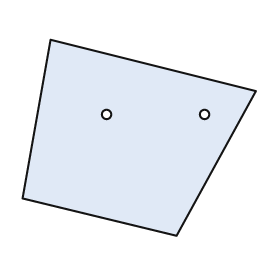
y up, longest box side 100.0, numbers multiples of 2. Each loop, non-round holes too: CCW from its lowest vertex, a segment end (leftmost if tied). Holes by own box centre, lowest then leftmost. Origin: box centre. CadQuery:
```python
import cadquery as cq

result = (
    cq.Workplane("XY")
    .moveTo(16.0, -42.0)
    .lineTo(50.0, 20.0)
    .lineTo(-38.0, 42.0)
    .lineTo(-50.0, -26.0)
    .close()
    .moveTo(-14.0, 10.0)
    .circle(2.0)
    .moveTo(28.0, 10.0)
    .circle(2.0)
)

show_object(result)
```